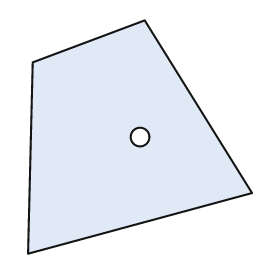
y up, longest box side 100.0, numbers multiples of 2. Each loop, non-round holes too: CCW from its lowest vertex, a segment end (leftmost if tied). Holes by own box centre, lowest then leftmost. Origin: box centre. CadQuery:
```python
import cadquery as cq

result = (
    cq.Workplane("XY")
    .moveTo(-48.0, -50.0)
    .lineTo(48.0, -24.0)
    .lineTo(2.0, 50.0)
    .lineTo(-46.0, 32.0)
    .close()
    .moveTo(0.0, 0.0)
    .circle(4.0)
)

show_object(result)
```